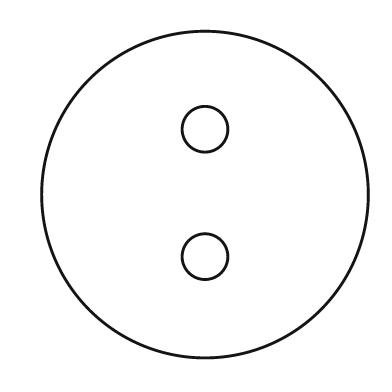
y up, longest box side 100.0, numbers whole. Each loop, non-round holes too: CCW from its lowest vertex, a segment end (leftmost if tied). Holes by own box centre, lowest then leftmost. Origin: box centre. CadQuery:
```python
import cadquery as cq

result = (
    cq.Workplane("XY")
    .moveTo(0.0, 0.0)
    .circle(50.0)
    .moveTo(0.0, -19.0)
    .circle(7.0)
    .moveTo(0.0, 20.0)
    .circle(7.0)
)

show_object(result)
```